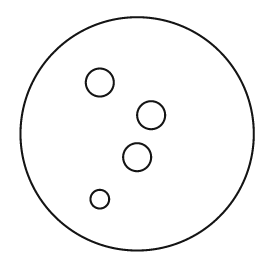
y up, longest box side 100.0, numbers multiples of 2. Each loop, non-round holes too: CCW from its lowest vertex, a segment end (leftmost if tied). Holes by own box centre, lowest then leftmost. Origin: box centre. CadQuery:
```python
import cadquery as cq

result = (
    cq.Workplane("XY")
    .moveTo(0.0, 0.0)
    .circle(50.0)
    .moveTo(-16.0, -28.0)
    .circle(4.0)
    .moveTo(0.0, -10.0)
    .circle(6.0)
    .moveTo(6.0, 8.0)
    .circle(6.0)
    .moveTo(-16.0, 22.0)
    .circle(6.0)
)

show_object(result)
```